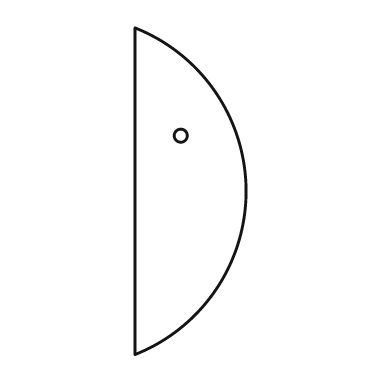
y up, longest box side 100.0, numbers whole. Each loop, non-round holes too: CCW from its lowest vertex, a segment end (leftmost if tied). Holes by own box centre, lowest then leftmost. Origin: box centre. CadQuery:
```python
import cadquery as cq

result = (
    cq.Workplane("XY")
    .moveTo(-17.0, -50.0)
    .threePointArc((17.0, 0.0), (-17.0, 50.0))
    .close()
    .moveTo(-3.0, 17.0)
    .circle(2.0)
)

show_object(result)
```